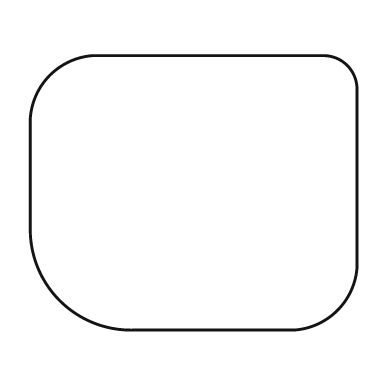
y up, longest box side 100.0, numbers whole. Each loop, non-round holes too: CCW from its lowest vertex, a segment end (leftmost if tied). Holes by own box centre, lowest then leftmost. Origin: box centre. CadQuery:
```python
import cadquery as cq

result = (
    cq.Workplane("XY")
    .moveTo(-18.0, -42.0)
    .lineTo(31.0, -42.0)
    .threePointArc((44.0, -36.0), (50.0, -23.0))
    .lineTo(50.0, 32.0)
    .threePointArc((47.0, 39.0), (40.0, 42.0))
    .lineTo(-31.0, 42.0)
    .threePointArc((-44.0, 36.0), (-50.0, 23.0))
    .lineTo(-50.0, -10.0)
    .threePointArc((-41.0, -33.0), (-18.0, -42.0))
    .close()
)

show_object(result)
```